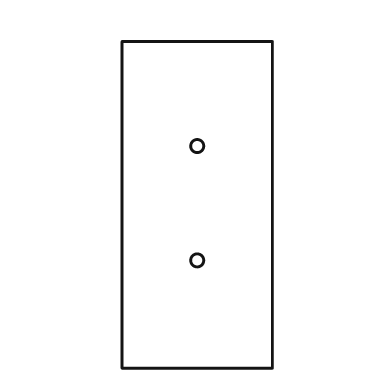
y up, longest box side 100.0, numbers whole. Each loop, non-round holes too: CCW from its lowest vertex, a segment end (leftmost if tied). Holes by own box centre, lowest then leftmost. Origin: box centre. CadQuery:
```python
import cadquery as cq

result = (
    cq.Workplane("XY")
    .moveTo(-23.0, -50.0)
    .lineTo(23.0, -50.0)
    .lineTo(23.0, 50.0)
    .lineTo(-23.0, 50.0)
    .close()
    .moveTo(0.0, -17.0)
    .circle(2.0)
    .moveTo(0.0, 18.0)
    .circle(2.0)
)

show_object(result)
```